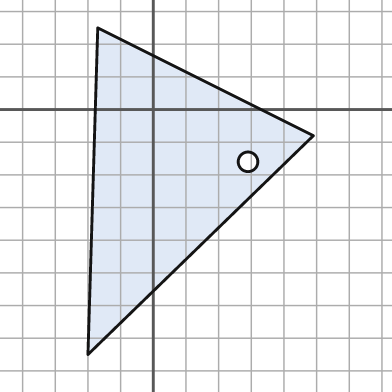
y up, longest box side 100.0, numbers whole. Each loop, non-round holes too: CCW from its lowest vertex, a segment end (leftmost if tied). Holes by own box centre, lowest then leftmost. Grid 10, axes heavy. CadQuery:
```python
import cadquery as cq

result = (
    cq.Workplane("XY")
    .moveTo(-20.0, -75.0)
    .lineTo(49.0, -8.0)
    .lineTo(-17.0, 25.0)
    .close()
    .moveTo(29.0, -16.0)
    .circle(3.0)
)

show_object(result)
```